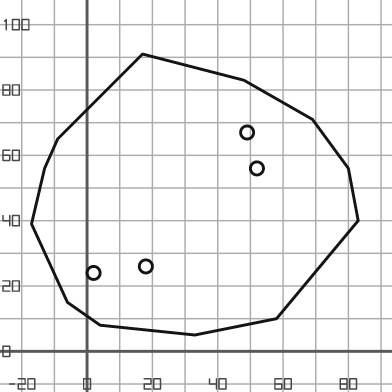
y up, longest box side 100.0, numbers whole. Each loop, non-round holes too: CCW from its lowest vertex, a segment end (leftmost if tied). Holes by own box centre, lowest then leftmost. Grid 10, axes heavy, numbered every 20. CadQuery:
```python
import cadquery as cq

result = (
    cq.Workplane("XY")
    .moveTo(33.0, 5.0)
    .lineTo(58.0, 10.0)
    .lineTo(83.0, 40.0)
    .lineTo(80.0, 56.0)
    .lineTo(69.0, 71.0)
    .lineTo(48.0, 83.0)
    .lineTo(17.0, 91.0)
    .lineTo(-9.0, 65.0)
    .lineTo(-13.0, 56.0)
    .lineTo(-17.0, 39.0)
    .lineTo(-6.0, 15.0)
    .lineTo(4.0, 8.0)
    .close()
    .moveTo(2.0, 24.0)
    .circle(2.0)
    .moveTo(18.0, 26.0)
    .circle(2.0)
    .moveTo(52.0, 56.0)
    .circle(2.0)
    .moveTo(49.0, 67.0)
    .circle(2.0)
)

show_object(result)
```